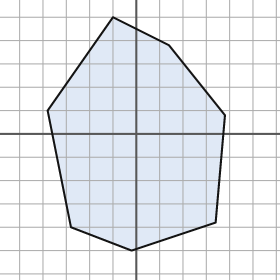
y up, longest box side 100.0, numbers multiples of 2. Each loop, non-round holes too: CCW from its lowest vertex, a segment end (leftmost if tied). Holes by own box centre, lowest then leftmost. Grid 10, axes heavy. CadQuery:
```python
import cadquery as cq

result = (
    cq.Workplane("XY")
    .moveTo(-2.0, -50.0)
    .lineTo(34.0, -38.0)
    .lineTo(38.0, 8.0)
    .lineTo(14.0, 38.0)
    .lineTo(-10.0, 50.0)
    .lineTo(-38.0, 10.0)
    .lineTo(-28.0, -40.0)
    .close()
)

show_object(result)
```